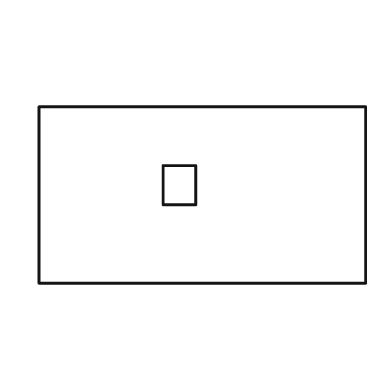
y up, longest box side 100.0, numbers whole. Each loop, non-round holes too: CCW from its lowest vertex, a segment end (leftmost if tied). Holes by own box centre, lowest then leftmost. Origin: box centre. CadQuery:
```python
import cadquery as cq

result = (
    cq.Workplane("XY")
    .moveTo(-50.0, -27.0)
    .lineTo(50.0, -27.0)
    .lineTo(50.0, 27.0)
    .lineTo(-50.0, 27.0)
    .close()
    .moveTo(-12.0, -3.0)
    .lineTo(-2.0, -3.0)
    .lineTo(-2.0, 9.0)
    .lineTo(-12.0, 9.0)
    .close()
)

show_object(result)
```